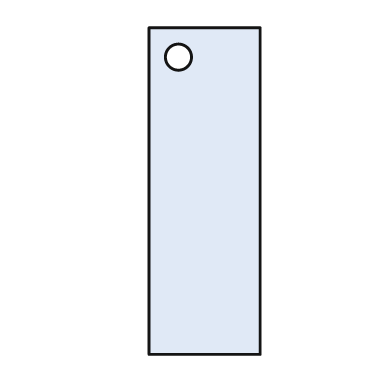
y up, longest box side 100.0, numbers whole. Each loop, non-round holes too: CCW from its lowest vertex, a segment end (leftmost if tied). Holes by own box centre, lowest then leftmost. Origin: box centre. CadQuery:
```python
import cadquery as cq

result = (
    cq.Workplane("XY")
    .moveTo(-17.0, -50.0)
    .lineTo(17.0, -50.0)
    .lineTo(17.0, 50.0)
    .lineTo(-17.0, 50.0)
    .close()
    .moveTo(-8.0, 41.0)
    .circle(4.0)
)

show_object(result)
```